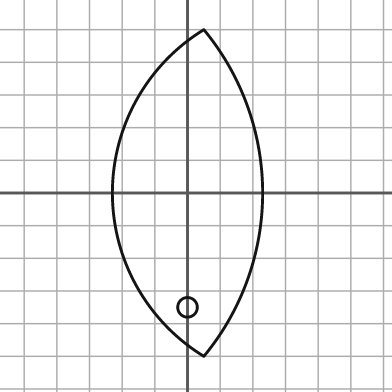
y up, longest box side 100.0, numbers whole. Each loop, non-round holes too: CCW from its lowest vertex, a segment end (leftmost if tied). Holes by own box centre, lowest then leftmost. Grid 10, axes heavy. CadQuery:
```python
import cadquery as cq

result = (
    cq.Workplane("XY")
    .moveTo(5.0, -50.0)
    .threePointArc((23.0, 0.0), (5.0, 50.0))
    .threePointArc((-23.0, 0.0), (5.0, -50.0))
    .close()
    .moveTo(0.0, -35.0)
    .circle(3.0)
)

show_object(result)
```